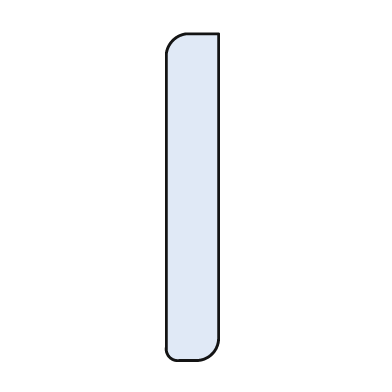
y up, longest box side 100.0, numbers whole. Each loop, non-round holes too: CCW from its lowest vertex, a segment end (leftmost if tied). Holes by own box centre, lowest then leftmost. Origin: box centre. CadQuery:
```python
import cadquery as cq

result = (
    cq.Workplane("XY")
    .moveTo(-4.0, -50.0)
    .lineTo(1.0, -50.0)
    .threePointArc((6.0, -48.0), (8.0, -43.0))
    .lineTo(8.0, 50.0)
    .lineTo(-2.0, 50.0)
    .threePointArc((-6.0, 48.0), (-8.0, 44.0))
    .lineTo(-8.0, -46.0)
    .threePointArc((-7.0, -49.0), (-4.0, -50.0))
    .close()
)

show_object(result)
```